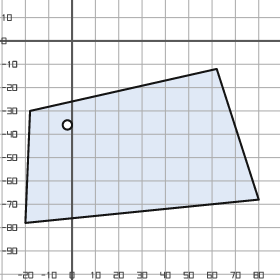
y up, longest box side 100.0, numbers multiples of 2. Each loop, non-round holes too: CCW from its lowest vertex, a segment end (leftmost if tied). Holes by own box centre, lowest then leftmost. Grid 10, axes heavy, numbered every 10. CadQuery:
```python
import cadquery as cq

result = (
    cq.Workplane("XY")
    .moveTo(-20.0, -78.0)
    .lineTo(80.0, -68.0)
    .lineTo(62.0, -12.0)
    .lineTo(-18.0, -30.0)
    .close()
    .moveTo(-2.0, -36.0)
    .circle(2.0)
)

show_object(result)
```